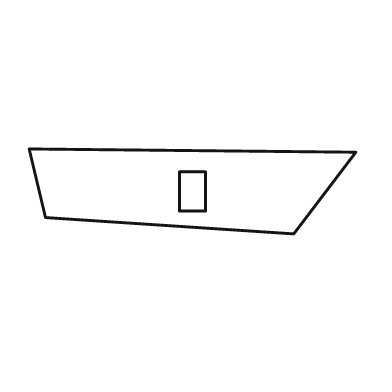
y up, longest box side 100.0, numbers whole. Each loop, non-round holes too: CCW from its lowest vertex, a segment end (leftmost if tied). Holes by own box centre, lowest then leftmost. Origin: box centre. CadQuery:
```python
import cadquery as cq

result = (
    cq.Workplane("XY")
    .moveTo(31.0, -13.0)
    .lineTo(50.0, 12.0)
    .lineTo(-50.0, 13.0)
    .lineTo(-45.0, -8.0)
    .close()
    .moveTo(-4.0, -6.0)
    .lineTo(4.0, -6.0)
    .lineTo(4.0, 6.0)
    .lineTo(-4.0, 6.0)
    .close()
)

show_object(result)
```